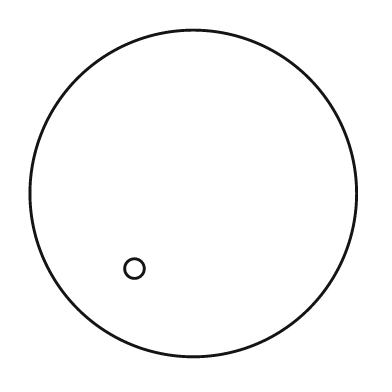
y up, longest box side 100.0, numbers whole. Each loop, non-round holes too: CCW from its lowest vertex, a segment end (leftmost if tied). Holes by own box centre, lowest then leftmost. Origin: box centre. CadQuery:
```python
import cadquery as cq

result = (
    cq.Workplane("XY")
    .moveTo(0.0, 0.0)
    .circle(50.0)
    .moveTo(-18.0, -23.0)
    .circle(3.0)
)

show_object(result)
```